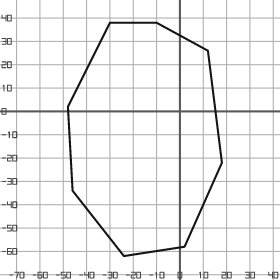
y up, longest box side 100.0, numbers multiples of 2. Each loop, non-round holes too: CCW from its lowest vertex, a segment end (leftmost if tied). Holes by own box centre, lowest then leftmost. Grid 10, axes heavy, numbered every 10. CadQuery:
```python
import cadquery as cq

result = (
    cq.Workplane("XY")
    .moveTo(-24.0, -62.0)
    .lineTo(2.0, -58.0)
    .lineTo(18.0, -22.0)
    .lineTo(12.0, 26.0)
    .lineTo(-10.0, 38.0)
    .lineTo(-30.0, 38.0)
    .lineTo(-48.0, 2.0)
    .lineTo(-46.0, -34.0)
    .close()
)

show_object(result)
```